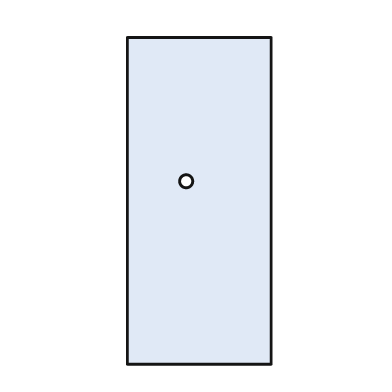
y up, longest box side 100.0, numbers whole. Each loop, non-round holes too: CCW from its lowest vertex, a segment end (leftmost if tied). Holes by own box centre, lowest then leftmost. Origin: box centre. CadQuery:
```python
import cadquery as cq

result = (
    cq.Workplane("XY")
    .moveTo(-22.0, -50.0)
    .lineTo(22.0, -50.0)
    .lineTo(22.0, 50.0)
    .lineTo(-22.0, 50.0)
    .close()
    .moveTo(-4.0, 6.0)
    .circle(2.0)
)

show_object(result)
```